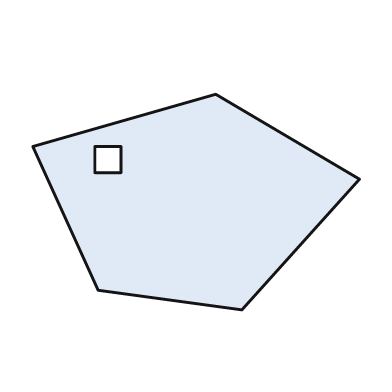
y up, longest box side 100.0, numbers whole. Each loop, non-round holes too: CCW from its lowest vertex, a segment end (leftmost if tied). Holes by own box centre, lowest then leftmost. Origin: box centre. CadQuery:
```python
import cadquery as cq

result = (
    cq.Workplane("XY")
    .moveTo(14.0, -33.0)
    .lineTo(50.0, 7.0)
    .lineTo(6.0, 33.0)
    .lineTo(-50.0, 17.0)
    .lineTo(-30.0, -27.0)
    .close()
    .moveTo(-31.0, 9.0)
    .lineTo(-23.0, 9.0)
    .lineTo(-23.0, 17.0)
    .lineTo(-31.0, 17.0)
    .close()
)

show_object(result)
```